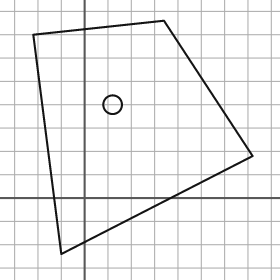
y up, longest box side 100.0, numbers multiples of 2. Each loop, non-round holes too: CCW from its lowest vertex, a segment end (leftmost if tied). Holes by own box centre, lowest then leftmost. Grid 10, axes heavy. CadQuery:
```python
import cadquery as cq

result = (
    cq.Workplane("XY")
    .moveTo(-10.0, -24.0)
    .lineTo(72.0, 18.0)
    .lineTo(34.0, 76.0)
    .lineTo(-22.0, 70.0)
    .close()
    .moveTo(12.0, 40.0)
    .circle(4.0)
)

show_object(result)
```